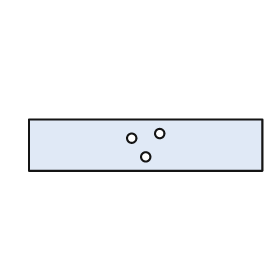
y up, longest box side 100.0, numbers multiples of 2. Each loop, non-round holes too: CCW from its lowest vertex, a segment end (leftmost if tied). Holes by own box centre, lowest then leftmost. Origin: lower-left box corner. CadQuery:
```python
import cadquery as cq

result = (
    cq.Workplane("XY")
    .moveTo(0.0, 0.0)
    .lineTo(100.0, 0.0)
    .lineTo(100.0, 22.0)
    .lineTo(0.0, 22.0)
    .close()
    .moveTo(50.0, 6.0)
    .circle(2.0)
    .moveTo(44.0, 14.0)
    .circle(2.0)
    .moveTo(56.0, 16.0)
    .circle(2.0)
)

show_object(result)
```